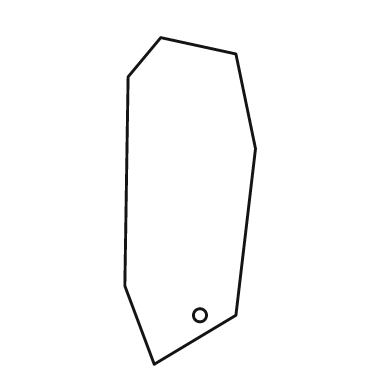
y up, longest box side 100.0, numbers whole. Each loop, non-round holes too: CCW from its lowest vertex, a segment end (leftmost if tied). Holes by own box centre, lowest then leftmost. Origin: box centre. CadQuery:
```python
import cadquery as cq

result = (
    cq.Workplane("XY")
    .moveTo(-11.0, -50.0)
    .lineTo(14.0, -35.0)
    .lineTo(20.0, 16.0)
    .lineTo(14.0, 45.0)
    .lineTo(-9.0, 50.0)
    .lineTo(-19.0, 38.0)
    .lineTo(-20.0, -26.0)
    .close()
    .moveTo(3.0, -35.0)
    .circle(2.0)
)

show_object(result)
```